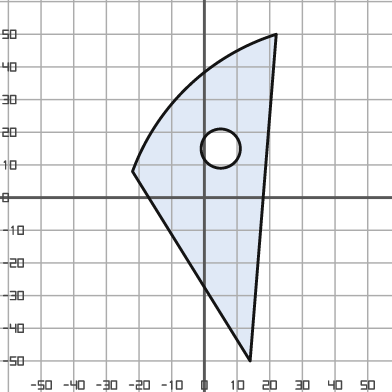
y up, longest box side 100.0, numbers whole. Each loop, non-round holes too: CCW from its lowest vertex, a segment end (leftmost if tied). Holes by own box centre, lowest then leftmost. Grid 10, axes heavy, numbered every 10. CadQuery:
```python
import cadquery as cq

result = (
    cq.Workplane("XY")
    .moveTo(14.0, -50.0)
    .lineTo(22.0, 50.0)
    .threePointArc((-5.0, 34.0), (-22.0, 8.0))
    .close()
    .moveTo(5.0, 15.0)
    .circle(6.0)
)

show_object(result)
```